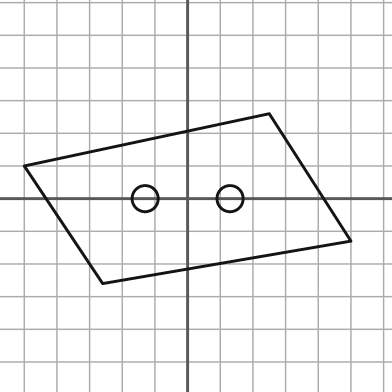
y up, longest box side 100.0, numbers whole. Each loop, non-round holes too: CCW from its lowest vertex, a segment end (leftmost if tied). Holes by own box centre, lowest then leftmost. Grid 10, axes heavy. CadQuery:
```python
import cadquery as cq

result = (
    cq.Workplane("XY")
    .moveTo(-26.0, -26.0)
    .lineTo(50.0, -13.0)
    .lineTo(25.0, 26.0)
    .lineTo(-50.0, 10.0)
    .close()
    .moveTo(-13.0, 0.0)
    .circle(4.0)
    .moveTo(13.0, 0.0)
    .circle(4.0)
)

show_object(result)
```